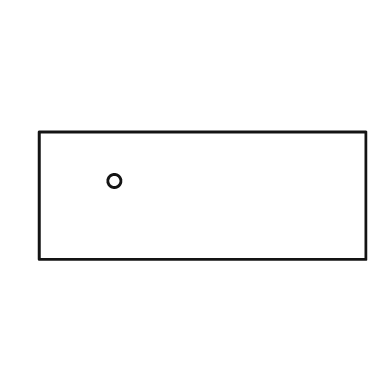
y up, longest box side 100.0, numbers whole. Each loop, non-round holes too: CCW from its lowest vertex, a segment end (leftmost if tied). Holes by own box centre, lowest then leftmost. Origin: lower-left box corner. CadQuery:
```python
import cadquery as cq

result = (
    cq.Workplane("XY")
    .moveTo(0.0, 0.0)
    .lineTo(100.0, 0.0)
    .lineTo(100.0, 39.0)
    .lineTo(0.0, 39.0)
    .close()
    .moveTo(23.0, 24.0)
    .circle(2.0)
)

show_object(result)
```